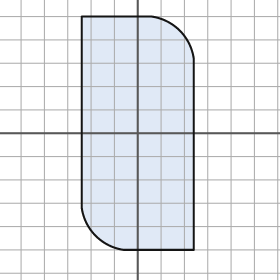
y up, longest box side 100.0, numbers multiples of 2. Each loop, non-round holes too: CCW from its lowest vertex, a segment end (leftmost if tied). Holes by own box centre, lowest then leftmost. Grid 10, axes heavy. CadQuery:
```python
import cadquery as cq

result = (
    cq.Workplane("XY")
    .moveTo(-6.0, -50.0)
    .lineTo(24.0, -50.0)
    .lineTo(24.0, 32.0)
    .threePointArc((18.0, 44.0), (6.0, 50.0))
    .lineTo(-24.0, 50.0)
    .lineTo(-24.0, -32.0)
    .threePointArc((-18.0, -44.0), (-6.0, -50.0))
    .close()
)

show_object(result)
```